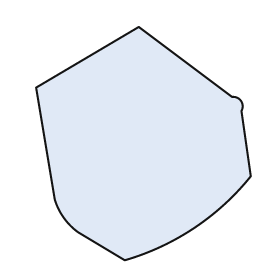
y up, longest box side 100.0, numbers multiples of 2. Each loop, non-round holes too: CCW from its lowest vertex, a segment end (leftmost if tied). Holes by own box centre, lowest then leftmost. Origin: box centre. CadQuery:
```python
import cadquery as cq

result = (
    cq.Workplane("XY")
    .moveTo(-8.0, -50.0)
    .threePointArc((22.0, -36.0), (46.0, -14.0))
    .lineTo(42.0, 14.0)
    .threePointArc((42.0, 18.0), (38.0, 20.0))
    .lineTo(-2.0, 50.0)
    .lineTo(-46.0, 24.0)
    .lineTo(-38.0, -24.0)
    .threePointArc((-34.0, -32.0), (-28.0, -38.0))
    .close()
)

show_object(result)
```